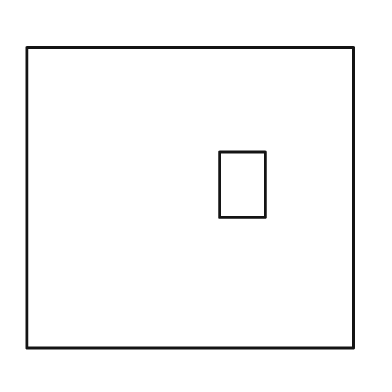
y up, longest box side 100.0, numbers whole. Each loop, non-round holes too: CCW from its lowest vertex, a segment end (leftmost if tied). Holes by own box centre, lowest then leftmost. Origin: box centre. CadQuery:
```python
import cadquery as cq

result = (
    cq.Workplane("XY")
    .moveTo(-50.0, -46.0)
    .lineTo(50.0, -46.0)
    .lineTo(50.0, 46.0)
    .lineTo(-50.0, 46.0)
    .close()
    .moveTo(9.0, -6.0)
    .lineTo(23.0, -6.0)
    .lineTo(23.0, 14.0)
    .lineTo(9.0, 14.0)
    .close()
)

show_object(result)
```